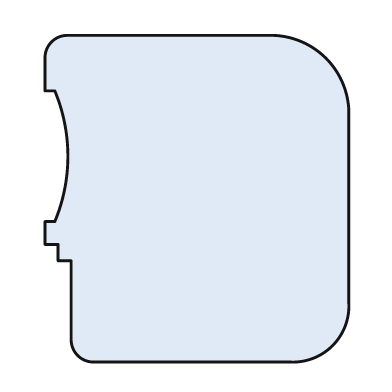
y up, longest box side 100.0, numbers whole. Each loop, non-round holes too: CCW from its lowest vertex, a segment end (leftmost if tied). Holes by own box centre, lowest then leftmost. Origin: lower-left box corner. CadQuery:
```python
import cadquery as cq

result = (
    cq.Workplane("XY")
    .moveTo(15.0, 0.0)
    .lineTo(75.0, 0.0)
    .threePointArc((88.0, 5.0), (93.0, 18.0))
    .lineTo(93.0, 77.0)
    .threePointArc((86.0, 93.0), (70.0, 100.0))
    .lineTo(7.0, 100.0)
    .threePointArc((2.0, 98.0), (0.0, 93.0))
    .lineTo(0.0, 83.0)
    .lineTo(3.0, 83.0)
    .threePointArc((7.0, 63.0), (3.0, 43.0))
    .lineTo(0.0, 43.0)
    .lineTo(0.0, 36.0)
    .lineTo(4.0, 36.0)
    .lineTo(4.0, 31.0)
    .lineTo(8.0, 31.0)
    .lineTo(8.0, 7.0)
    .threePointArc((10.0, 2.0), (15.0, 0.0))
    .close()
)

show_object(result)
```